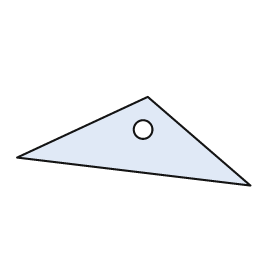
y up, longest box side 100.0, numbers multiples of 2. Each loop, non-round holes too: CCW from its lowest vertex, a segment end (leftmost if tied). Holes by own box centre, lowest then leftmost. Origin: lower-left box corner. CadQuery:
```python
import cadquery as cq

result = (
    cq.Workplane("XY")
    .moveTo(100.0, 0.0)
    .lineTo(56.0, 38.0)
    .lineTo(0.0, 12.0)
    .close()
    .moveTo(54.0, 24.0)
    .circle(4.0)
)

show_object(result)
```